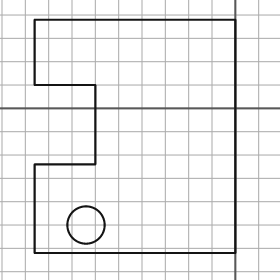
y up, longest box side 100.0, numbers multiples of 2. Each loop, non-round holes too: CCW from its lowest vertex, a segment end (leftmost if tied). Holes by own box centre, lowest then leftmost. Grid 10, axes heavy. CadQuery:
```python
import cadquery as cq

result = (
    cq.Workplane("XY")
    .moveTo(-86.0, -62.0)
    .lineTo(0.0, -62.0)
    .lineTo(0.0, 38.0)
    .lineTo(-86.0, 38.0)
    .lineTo(-86.0, 10.0)
    .lineTo(-60.0, 10.0)
    .lineTo(-60.0, -24.0)
    .lineTo(-86.0, -24.0)
    .close()
    .moveTo(-64.0, -50.0)
    .circle(8.0)
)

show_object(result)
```